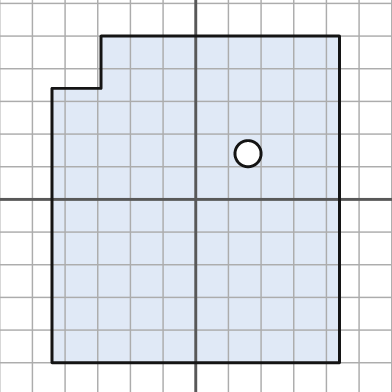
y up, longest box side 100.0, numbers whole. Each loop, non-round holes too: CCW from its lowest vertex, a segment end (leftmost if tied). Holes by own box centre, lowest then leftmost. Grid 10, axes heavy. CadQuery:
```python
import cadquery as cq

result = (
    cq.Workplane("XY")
    .moveTo(-44.0, -50.0)
    .lineTo(44.0, -50.0)
    .lineTo(44.0, 50.0)
    .lineTo(-29.0, 50.0)
    .lineTo(-29.0, 34.0)
    .lineTo(-44.0, 34.0)
    .close()
    .moveTo(16.0, 14.0)
    .circle(4.0)
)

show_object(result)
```